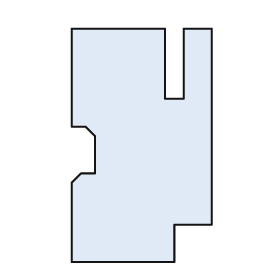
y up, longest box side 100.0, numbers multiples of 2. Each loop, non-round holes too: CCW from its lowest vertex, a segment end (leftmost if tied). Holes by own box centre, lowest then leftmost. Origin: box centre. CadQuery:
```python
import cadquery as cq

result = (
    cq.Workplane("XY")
    .moveTo(-30.0, -50.0)
    .lineTo(14.0, -50.0)
    .lineTo(14.0, -34.0)
    .lineTo(30.0, -34.0)
    .lineTo(30.0, 50.0)
    .lineTo(18.0, 50.0)
    .lineTo(18.0, 20.0)
    .lineTo(10.0, 20.0)
    .lineTo(10.0, 50.0)
    .lineTo(-30.0, 50.0)
    .lineTo(-30.0, 8.0)
    .lineTo(-24.0, 8.0)
    .lineTo(-20.0, 4.0)
    .lineTo(-20.0, -12.0)
    .lineTo(-26.0, -12.0)
    .lineTo(-30.0, -16.0)
    .close()
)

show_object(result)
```